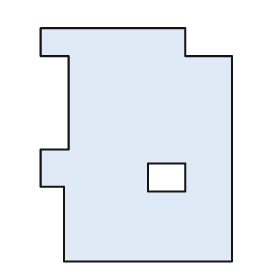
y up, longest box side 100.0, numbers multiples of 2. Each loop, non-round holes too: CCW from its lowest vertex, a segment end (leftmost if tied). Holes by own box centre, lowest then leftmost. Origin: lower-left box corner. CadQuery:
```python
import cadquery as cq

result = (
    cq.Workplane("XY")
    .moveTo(10.0, 0.0)
    .lineTo(82.0, 0.0)
    .lineTo(82.0, 88.0)
    .lineTo(62.0, 88.0)
    .lineTo(62.0, 100.0)
    .lineTo(0.0, 100.0)
    .lineTo(0.0, 88.0)
    .lineTo(12.0, 88.0)
    .lineTo(12.0, 48.0)
    .lineTo(0.0, 48.0)
    .lineTo(0.0, 32.0)
    .lineTo(10.0, 32.0)
    .close()
    .moveTo(46.0, 30.0)
    .lineTo(62.0, 30.0)
    .lineTo(62.0, 42.0)
    .lineTo(46.0, 42.0)
    .close()
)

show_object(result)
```